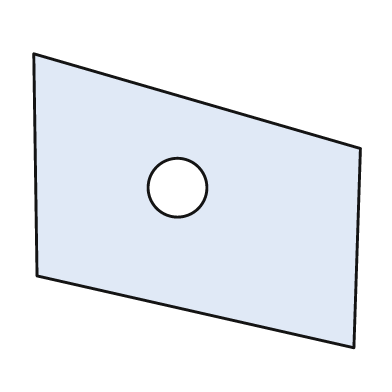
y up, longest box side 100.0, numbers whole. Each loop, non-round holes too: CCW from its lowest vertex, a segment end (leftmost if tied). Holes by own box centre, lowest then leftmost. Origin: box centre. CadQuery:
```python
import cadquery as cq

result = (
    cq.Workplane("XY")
    .moveTo(48.0, -45.0)
    .lineTo(50.0, 16.0)
    .lineTo(-50.0, 45.0)
    .lineTo(-49.0, -23.0)
    .close()
    .moveTo(-6.0, 4.0)
    .circle(9.0)
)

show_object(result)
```